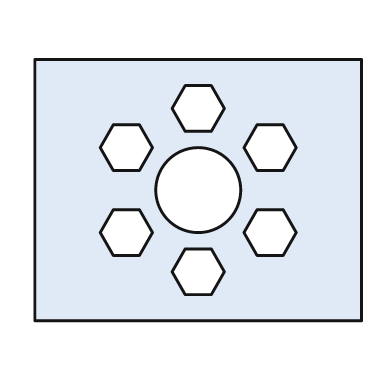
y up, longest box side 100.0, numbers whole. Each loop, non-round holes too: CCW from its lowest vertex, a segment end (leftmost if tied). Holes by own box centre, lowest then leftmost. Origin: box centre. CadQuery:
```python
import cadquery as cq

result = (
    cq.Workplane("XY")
    .moveTo(-50.0, -40.0)
    .lineTo(50.0, -40.0)
    .lineTo(50.0, 40.0)
    .lineTo(-50.0, 40.0)
    .close()
    .moveTo(-4.0, -32.0)
    .lineTo(4.0, -32.0)
    .lineTo(8.0, -25.0)
    .lineTo(4.0, -18.0)
    .lineTo(-4.0, -18.0)
    .lineTo(-8.0, -25.0)
    .close()
    .moveTo(-26.0, -20.0)
    .lineTo(-18.0, -20.0)
    .lineTo(-14.0, -13.0)
    .lineTo(-18.0, -6.0)
    .lineTo(-26.0, -6.0)
    .lineTo(-30.0, -13.0)
    .close()
    .moveTo(18.0, -20.0)
    .lineTo(26.0, -20.0)
    .lineTo(30.0, -13.0)
    .lineTo(26.0, -6.0)
    .lineTo(18.0, -6.0)
    .lineTo(14.0, -13.0)
    .close()
    .moveTo(0.0, 0.0)
    .circle(13.0)
    .moveTo(-26.0, 6.0)
    .lineTo(-18.0, 6.0)
    .lineTo(-14.0, 13.0)
    .lineTo(-18.0, 20.0)
    .lineTo(-26.0, 20.0)
    .lineTo(-30.0, 13.0)
    .close()
    .moveTo(18.0, 6.0)
    .lineTo(26.0, 6.0)
    .lineTo(30.0, 13.0)
    .lineTo(26.0, 20.0)
    .lineTo(18.0, 20.0)
    .lineTo(14.0, 13.0)
    .close()
    .moveTo(-4.0, 18.0)
    .lineTo(4.0, 18.0)
    .lineTo(8.0, 25.0)
    .lineTo(4.0, 32.0)
    .lineTo(-4.0, 32.0)
    .lineTo(-8.0, 25.0)
    .close()
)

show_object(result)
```